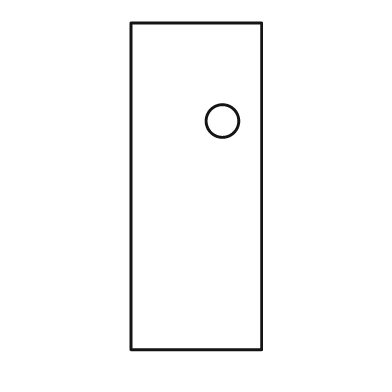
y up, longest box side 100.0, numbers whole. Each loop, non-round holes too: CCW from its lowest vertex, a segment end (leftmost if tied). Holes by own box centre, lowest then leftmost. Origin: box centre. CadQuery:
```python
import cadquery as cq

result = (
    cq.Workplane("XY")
    .moveTo(-20.0, -50.0)
    .lineTo(20.0, -50.0)
    .lineTo(20.0, 50.0)
    .lineTo(-20.0, 50.0)
    .close()
    .moveTo(8.0, 20.0)
    .circle(5.0)
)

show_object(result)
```